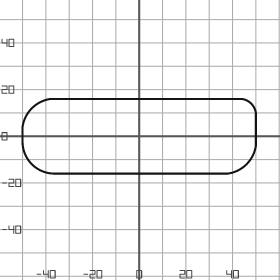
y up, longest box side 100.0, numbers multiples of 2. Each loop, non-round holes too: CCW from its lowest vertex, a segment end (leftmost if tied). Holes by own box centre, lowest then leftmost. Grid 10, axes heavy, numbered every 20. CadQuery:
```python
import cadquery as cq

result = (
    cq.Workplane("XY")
    .moveTo(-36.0, -16.0)
    .lineTo(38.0, -16.0)
    .threePointArc((46.0, -12.0), (50.0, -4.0))
    .lineTo(50.0, 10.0)
    .threePointArc((48.0, 14.0), (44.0, 16.0))
    .lineTo(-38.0, 16.0)
    .threePointArc((-46.0, 12.0), (-50.0, 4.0))
    .lineTo(-50.0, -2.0)
    .threePointArc((-46.0, -12.0), (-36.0, -16.0))
    .close()
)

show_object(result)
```